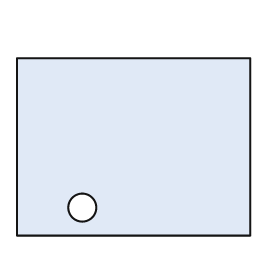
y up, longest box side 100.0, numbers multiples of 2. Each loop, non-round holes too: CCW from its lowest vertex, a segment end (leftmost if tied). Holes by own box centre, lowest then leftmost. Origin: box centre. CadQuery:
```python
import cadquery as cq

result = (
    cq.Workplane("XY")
    .moveTo(-50.0, -38.0)
    .lineTo(50.0, -38.0)
    .lineTo(50.0, 38.0)
    .lineTo(-50.0, 38.0)
    .close()
    .moveTo(-22.0, -26.0)
    .circle(6.0)
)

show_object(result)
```